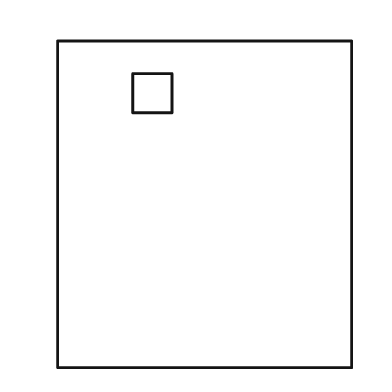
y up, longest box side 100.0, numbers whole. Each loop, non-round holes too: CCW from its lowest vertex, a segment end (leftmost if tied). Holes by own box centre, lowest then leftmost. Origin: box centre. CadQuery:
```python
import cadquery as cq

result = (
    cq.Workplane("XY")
    .moveTo(-45.0, -50.0)
    .lineTo(45.0, -50.0)
    .lineTo(45.0, 50.0)
    .lineTo(-45.0, 50.0)
    .close()
    .moveTo(-22.0, 28.0)
    .lineTo(-10.0, 28.0)
    .lineTo(-10.0, 40.0)
    .lineTo(-22.0, 40.0)
    .close()
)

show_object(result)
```